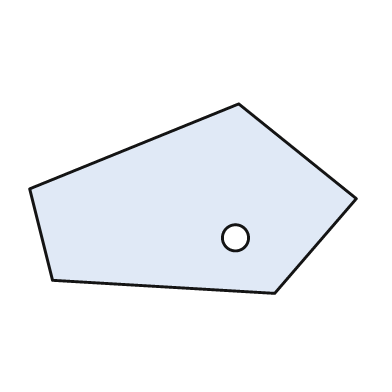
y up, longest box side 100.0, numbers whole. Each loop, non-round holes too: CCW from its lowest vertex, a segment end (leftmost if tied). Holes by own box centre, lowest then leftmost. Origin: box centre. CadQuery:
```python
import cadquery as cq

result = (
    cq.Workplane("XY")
    .moveTo(25.0, -29.0)
    .lineTo(50.0, 0.0)
    .lineTo(14.0, 29.0)
    .lineTo(-50.0, 3.0)
    .lineTo(-43.0, -25.0)
    .close()
    .moveTo(13.0, -12.0)
    .circle(4.0)
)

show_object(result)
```